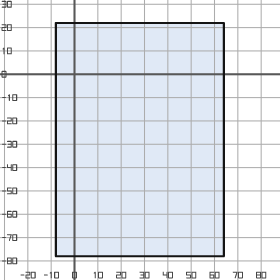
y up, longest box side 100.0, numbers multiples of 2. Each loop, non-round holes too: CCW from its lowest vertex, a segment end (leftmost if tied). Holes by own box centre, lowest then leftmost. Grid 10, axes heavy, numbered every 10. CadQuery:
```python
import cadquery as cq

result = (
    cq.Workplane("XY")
    .moveTo(-8.0, -78.0)
    .lineTo(64.0, -78.0)
    .lineTo(64.0, 22.0)
    .lineTo(-8.0, 22.0)
    .close()
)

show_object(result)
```